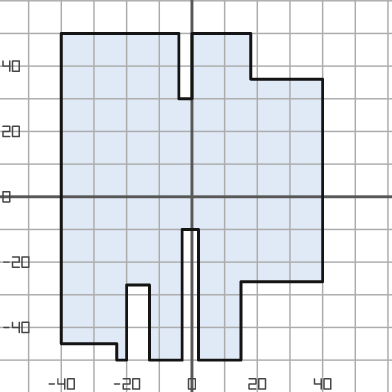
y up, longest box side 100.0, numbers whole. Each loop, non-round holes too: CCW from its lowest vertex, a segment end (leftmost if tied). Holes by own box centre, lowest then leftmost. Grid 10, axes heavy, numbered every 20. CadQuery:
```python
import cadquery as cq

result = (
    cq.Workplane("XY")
    .moveTo(-23.0, -50.0)
    .lineTo(-20.0, -50.0)
    .lineTo(-20.0, -27.0)
    .lineTo(-13.0, -27.0)
    .lineTo(-13.0, -50.0)
    .lineTo(-3.0, -50.0)
    .lineTo(-3.0, -10.0)
    .lineTo(2.0, -10.0)
    .lineTo(2.0, -50.0)
    .lineTo(15.0, -50.0)
    .lineTo(15.0, -26.0)
    .lineTo(40.0, -26.0)
    .lineTo(40.0, 36.0)
    .lineTo(18.0, 36.0)
    .lineTo(18.0, 50.0)
    .lineTo(0.0, 50.0)
    .lineTo(0.0, 30.0)
    .lineTo(-4.0, 30.0)
    .lineTo(-4.0, 50.0)
    .lineTo(-40.0, 50.0)
    .lineTo(-40.0, -45.0)
    .lineTo(-23.0, -45.0)
    .close()
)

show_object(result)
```